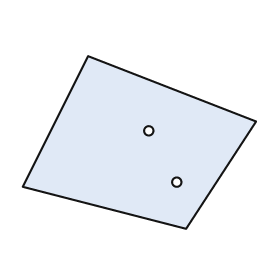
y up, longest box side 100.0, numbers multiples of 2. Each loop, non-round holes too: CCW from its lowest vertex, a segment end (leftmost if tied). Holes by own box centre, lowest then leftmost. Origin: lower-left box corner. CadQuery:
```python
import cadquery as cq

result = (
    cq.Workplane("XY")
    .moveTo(70.0, 0.0)
    .lineTo(100.0, 46.0)
    .lineTo(28.0, 74.0)
    .lineTo(0.0, 18.0)
    .close()
    .moveTo(66.0, 20.0)
    .circle(2.0)
    .moveTo(54.0, 42.0)
    .circle(2.0)
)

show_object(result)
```